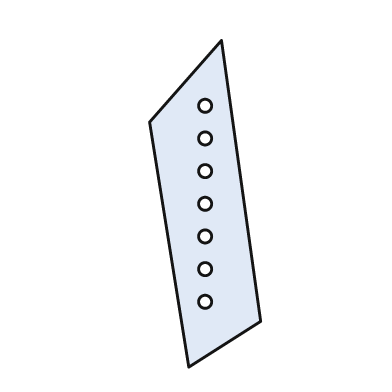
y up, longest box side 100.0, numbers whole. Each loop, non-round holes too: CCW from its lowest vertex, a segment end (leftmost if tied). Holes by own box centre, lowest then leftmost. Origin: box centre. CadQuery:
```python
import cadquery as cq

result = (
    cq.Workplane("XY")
    .moveTo(-5.0, -50.0)
    .lineTo(17.0, -36.0)
    .lineTo(5.0, 50.0)
    .lineTo(-17.0, 25.0)
    .close()
    .moveTo(0.0, -30.0)
    .circle(2.0)
    .moveTo(0.0, -20.0)
    .circle(2.0)
    .moveTo(0.0, -10.0)
    .circle(2.0)
    .moveTo(0.0, 0.0)
    .circle(2.0)
    .moveTo(0.0, 10.0)
    .circle(2.0)
    .moveTo(0.0, 20.0)
    .circle(2.0)
    .moveTo(0.0, 30.0)
    .circle(2.0)
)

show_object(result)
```